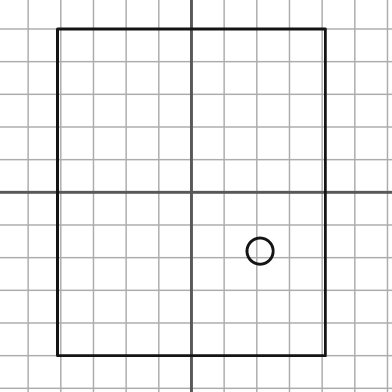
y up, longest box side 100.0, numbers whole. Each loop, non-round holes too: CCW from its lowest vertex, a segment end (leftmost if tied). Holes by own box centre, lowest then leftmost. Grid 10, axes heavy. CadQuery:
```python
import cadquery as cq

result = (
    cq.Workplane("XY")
    .moveTo(-41.0, -50.0)
    .lineTo(41.0, -50.0)
    .lineTo(41.0, 50.0)
    .lineTo(-41.0, 50.0)
    .close()
    .moveTo(21.0, -18.0)
    .circle(4.0)
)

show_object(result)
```